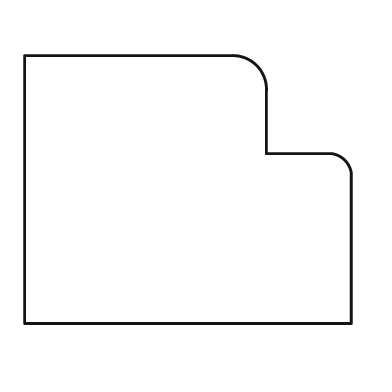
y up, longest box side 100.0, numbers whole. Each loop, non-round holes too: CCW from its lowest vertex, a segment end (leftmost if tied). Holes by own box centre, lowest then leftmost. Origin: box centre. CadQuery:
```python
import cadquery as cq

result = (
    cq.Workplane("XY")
    .moveTo(-50.0, -41.0)
    .lineTo(50.0, -41.0)
    .lineTo(50.0, 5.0)
    .threePointArc((48.0, 9.0), (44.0, 11.0))
    .lineTo(24.0, 11.0)
    .lineTo(24.0, 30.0)
    .threePointArc((21.0, 38.0), (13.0, 41.0))
    .lineTo(-50.0, 41.0)
    .close()
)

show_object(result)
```